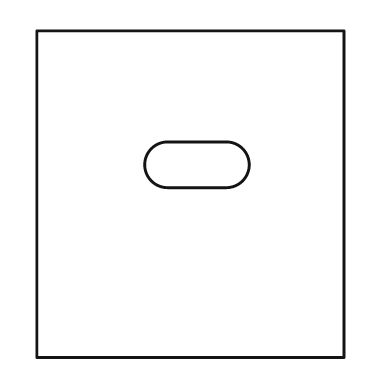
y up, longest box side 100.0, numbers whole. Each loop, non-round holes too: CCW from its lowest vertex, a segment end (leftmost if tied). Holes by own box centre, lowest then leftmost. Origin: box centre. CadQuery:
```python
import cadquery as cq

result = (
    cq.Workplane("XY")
    .moveTo(-47.0, -50.0)
    .lineTo(47.0, -50.0)
    .lineTo(47.0, 50.0)
    .lineTo(-47.0, 50.0)
    .close()
    .moveTo(-7.0, 2.0)
    .lineTo(11.0, 2.0)
    .threePointArc((18.0, 9.0), (11.0, 16.0))
    .lineTo(-7.0, 16.0)
    .threePointArc((-14.0, 9.0), (-7.0, 2.0))
    .close()
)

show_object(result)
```